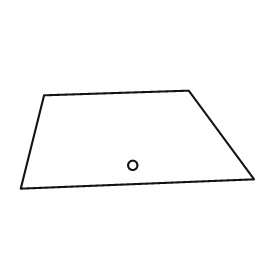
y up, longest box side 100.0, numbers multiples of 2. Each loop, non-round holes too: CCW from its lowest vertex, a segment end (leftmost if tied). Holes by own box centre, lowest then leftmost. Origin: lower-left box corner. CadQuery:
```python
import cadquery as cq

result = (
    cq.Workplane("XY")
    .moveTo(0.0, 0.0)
    .lineTo(100.0, 4.0)
    .lineTo(72.0, 42.0)
    .lineTo(10.0, 40.0)
    .close()
    .moveTo(48.0, 10.0)
    .circle(2.0)
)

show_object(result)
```